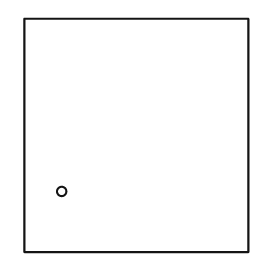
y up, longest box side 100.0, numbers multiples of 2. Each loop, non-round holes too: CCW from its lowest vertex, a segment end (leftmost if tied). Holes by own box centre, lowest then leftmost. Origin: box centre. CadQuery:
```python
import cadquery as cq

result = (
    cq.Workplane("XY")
    .moveTo(-48.0, -50.0)
    .lineTo(48.0, -50.0)
    .lineTo(48.0, 50.0)
    .lineTo(-48.0, 50.0)
    .close()
    .moveTo(-32.0, -24.0)
    .circle(2.0)
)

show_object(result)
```